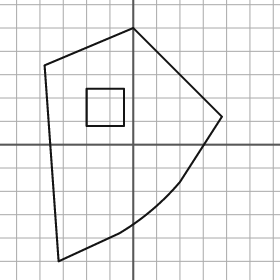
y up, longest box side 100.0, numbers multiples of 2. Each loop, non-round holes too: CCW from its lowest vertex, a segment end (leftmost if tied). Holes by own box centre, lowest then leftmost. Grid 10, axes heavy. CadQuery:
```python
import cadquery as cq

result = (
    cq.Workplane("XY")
    .moveTo(-32.0, -50.0)
    .lineTo(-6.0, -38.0)
    .threePointArc((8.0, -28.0), (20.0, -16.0))
    .lineTo(38.0, 12.0)
    .lineTo(0.0, 50.0)
    .lineTo(-38.0, 34.0)
    .close()
    .moveTo(-20.0, 8.0)
    .lineTo(-4.0, 8.0)
    .lineTo(-4.0, 24.0)
    .lineTo(-20.0, 24.0)
    .close()
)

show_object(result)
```